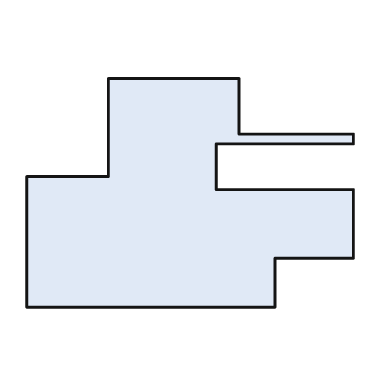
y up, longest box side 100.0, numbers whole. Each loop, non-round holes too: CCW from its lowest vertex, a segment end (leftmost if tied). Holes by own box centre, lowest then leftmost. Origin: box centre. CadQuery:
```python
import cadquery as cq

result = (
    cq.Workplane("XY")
    .moveTo(-50.0, -35.0)
    .lineTo(26.0, -35.0)
    .lineTo(26.0, -20.0)
    .lineTo(50.0, -20.0)
    .lineTo(50.0, 1.0)
    .lineTo(8.0, 1.0)
    .lineTo(8.0, 15.0)
    .lineTo(50.0, 15.0)
    .lineTo(50.0, 18.0)
    .lineTo(15.0, 18.0)
    .lineTo(15.0, 35.0)
    .lineTo(-25.0, 35.0)
    .lineTo(-25.0, 5.0)
    .lineTo(-50.0, 5.0)
    .close()
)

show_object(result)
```